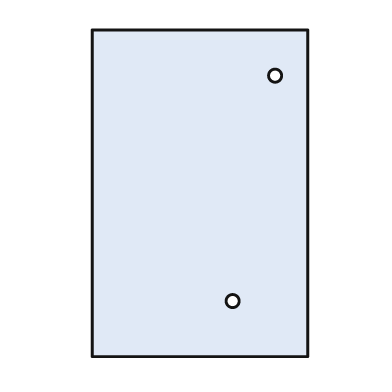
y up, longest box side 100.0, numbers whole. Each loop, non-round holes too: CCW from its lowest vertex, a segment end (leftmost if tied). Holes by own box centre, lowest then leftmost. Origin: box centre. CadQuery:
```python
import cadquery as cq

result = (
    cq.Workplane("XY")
    .moveTo(-33.0, -50.0)
    .lineTo(33.0, -50.0)
    .lineTo(33.0, 50.0)
    .lineTo(-33.0, 50.0)
    .close()
    .moveTo(10.0, -33.0)
    .circle(2.0)
    .moveTo(23.0, 36.0)
    .circle(2.0)
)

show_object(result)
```